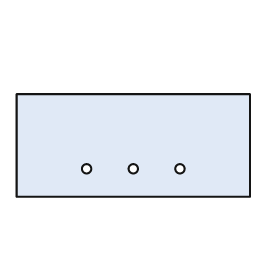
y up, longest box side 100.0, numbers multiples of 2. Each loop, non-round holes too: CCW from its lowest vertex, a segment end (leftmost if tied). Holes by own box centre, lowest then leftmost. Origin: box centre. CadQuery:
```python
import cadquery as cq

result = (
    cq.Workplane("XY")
    .moveTo(-50.0, -22.0)
    .lineTo(50.0, -22.0)
    .lineTo(50.0, 22.0)
    .lineTo(-50.0, 22.0)
    .close()
    .moveTo(-20.0, -10.0)
    .circle(2.0)
    .moveTo(0.0, -10.0)
    .circle(2.0)
    .moveTo(20.0, -10.0)
    .circle(2.0)
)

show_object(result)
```